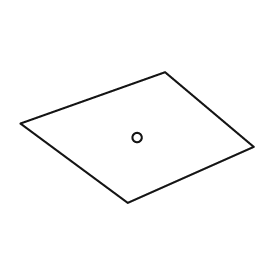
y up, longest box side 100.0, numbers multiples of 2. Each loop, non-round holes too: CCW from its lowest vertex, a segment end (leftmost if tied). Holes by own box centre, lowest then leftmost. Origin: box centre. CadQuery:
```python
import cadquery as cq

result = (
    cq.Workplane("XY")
    .moveTo(-4.0, -28.0)
    .lineTo(50.0, -4.0)
    .lineTo(12.0, 28.0)
    .lineTo(-50.0, 6.0)
    .close()
    .moveTo(0.0, 0.0)
    .circle(2.0)
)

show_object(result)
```